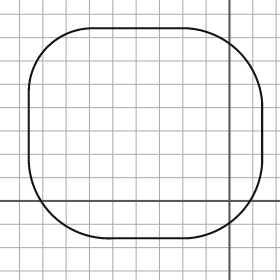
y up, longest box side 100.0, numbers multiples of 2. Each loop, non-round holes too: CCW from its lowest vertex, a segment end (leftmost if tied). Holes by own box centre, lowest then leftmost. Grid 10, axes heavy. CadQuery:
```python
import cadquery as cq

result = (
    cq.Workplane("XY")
    .moveTo(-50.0, -16.0)
    .lineTo(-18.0, -16.0)
    .threePointArc((4.0, -6.0), (14.0, 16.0))
    .lineTo(14.0, 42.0)
    .threePointArc((4.0, 64.0), (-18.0, 74.0))
    .lineTo(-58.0, 74.0)
    .threePointArc((-78.0, 66.0), (-86.0, 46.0))
    .lineTo(-86.0, 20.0)
    .threePointArc((-76.0, -6.0), (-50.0, -16.0))
    .close()
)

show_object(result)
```